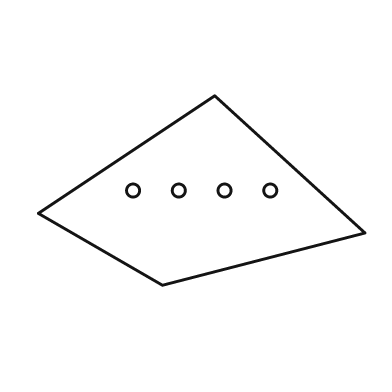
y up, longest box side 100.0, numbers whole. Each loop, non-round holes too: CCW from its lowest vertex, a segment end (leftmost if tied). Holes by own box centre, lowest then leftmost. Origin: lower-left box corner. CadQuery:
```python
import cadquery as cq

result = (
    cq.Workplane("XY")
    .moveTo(38.0, 0.0)
    .lineTo(100.0, 16.0)
    .lineTo(54.0, 58.0)
    .lineTo(0.0, 22.0)
    .close()
    .moveTo(29.0, 29.0)
    .circle(2.0)
    .moveTo(43.0, 29.0)
    .circle(2.0)
    .moveTo(57.0, 29.0)
    .circle(2.0)
    .moveTo(71.0, 29.0)
    .circle(2.0)
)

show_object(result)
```